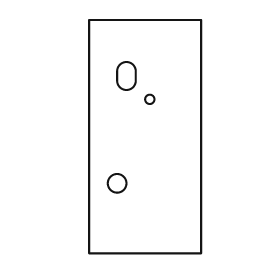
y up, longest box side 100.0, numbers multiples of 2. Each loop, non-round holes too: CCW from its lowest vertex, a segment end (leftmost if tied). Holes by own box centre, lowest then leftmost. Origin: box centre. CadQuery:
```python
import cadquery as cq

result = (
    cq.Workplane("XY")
    .moveTo(-24.0, -50.0)
    .lineTo(24.0, -50.0)
    .lineTo(24.0, 50.0)
    .lineTo(-24.0, 50.0)
    .close()
    .moveTo(-12.0, -20.0)
    .circle(4.0)
    .moveTo(2.0, 16.0)
    .circle(2.0)
    .moveTo(-12.0, 24.0)
    .threePointArc((-8.0, 20.0), (-4.0, 24.0))
    .lineTo(-4.0, 28.0)
    .threePointArc((-8.0, 32.0), (-12.0, 28.0))
    .close()
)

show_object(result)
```